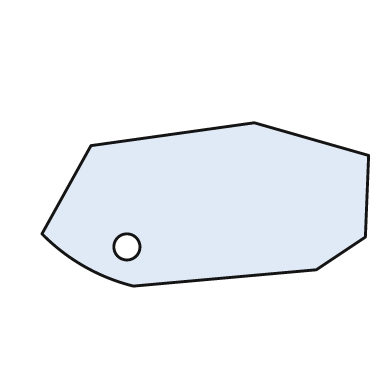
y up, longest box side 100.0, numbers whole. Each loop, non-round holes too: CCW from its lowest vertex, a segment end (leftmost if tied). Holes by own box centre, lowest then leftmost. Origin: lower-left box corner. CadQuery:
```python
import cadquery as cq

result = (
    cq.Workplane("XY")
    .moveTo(28.0, 0.0)
    .lineTo(84.0, 5.0)
    .lineTo(99.0, 15.0)
    .lineTo(100.0, 40.0)
    .lineTo(65.0, 50.0)
    .lineTo(15.0, 43.0)
    .lineTo(0.0, 16.0)
    .threePointArc((13.0, 6.0), (28.0, 0.0))
    .close()
    .moveTo(26.0, 12.0)
    .circle(4.0)
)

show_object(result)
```